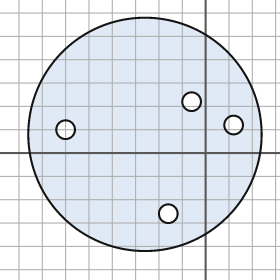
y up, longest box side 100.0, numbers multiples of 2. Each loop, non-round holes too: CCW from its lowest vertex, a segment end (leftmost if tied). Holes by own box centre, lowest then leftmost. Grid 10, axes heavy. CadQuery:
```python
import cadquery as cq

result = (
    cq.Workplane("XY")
    .moveTo(-26.0, 8.0)
    .circle(50.0)
    .moveTo(-16.0, -26.0)
    .circle(4.0)
    .moveTo(-60.0, 10.0)
    .circle(4.0)
    .moveTo(12.0, 12.0)
    .circle(4.0)
    .moveTo(-6.0, 22.0)
    .circle(4.0)
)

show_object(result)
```